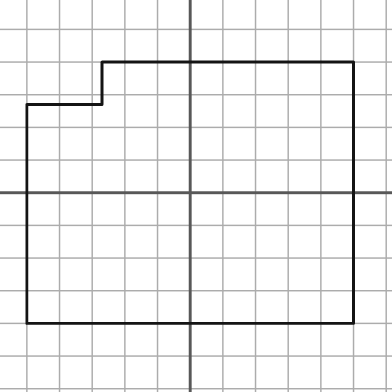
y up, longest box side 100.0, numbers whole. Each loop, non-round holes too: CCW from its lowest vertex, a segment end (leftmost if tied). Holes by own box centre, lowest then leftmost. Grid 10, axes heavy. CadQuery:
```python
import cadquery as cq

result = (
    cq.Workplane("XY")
    .moveTo(-50.0, -40.0)
    .lineTo(50.0, -40.0)
    .lineTo(50.0, 40.0)
    .lineTo(-27.0, 40.0)
    .lineTo(-27.0, 27.0)
    .lineTo(-50.0, 27.0)
    .close()
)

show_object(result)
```